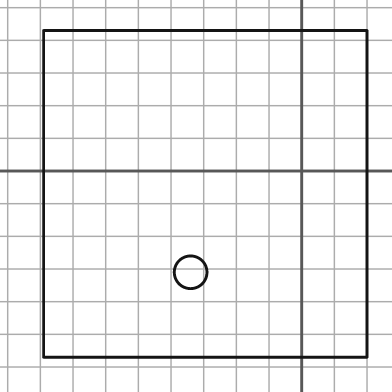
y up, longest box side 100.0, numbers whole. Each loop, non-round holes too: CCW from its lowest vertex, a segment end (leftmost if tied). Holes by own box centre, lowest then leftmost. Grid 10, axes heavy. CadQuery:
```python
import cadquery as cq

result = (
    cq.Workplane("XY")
    .moveTo(-79.0, -57.0)
    .lineTo(20.0, -57.0)
    .lineTo(20.0, 43.0)
    .lineTo(-79.0, 43.0)
    .close()
    .moveTo(-34.0, -31.0)
    .circle(5.0)
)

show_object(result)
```